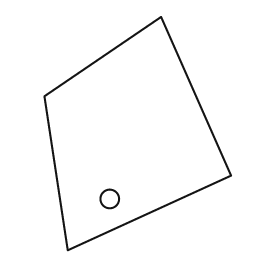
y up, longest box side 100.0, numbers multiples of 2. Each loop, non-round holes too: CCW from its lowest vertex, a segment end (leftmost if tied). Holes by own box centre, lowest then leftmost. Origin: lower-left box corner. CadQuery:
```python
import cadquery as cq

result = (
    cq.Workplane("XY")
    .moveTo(10.0, 0.0)
    .lineTo(80.0, 32.0)
    .lineTo(50.0, 100.0)
    .lineTo(0.0, 66.0)
    .close()
    .moveTo(28.0, 22.0)
    .circle(4.0)
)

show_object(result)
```